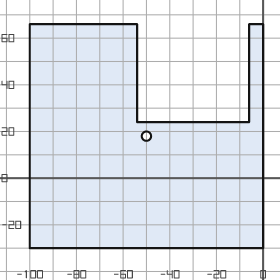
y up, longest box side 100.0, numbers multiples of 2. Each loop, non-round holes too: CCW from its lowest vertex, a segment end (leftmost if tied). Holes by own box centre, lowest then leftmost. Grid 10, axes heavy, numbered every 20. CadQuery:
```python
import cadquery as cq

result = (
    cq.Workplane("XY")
    .moveTo(-100.0, -30.0)
    .lineTo(0.0, -30.0)
    .lineTo(0.0, 66.0)
    .lineTo(-6.0, 66.0)
    .lineTo(-6.0, 24.0)
    .lineTo(-54.0, 24.0)
    .lineTo(-54.0, 66.0)
    .lineTo(-100.0, 66.0)
    .close()
    .moveTo(-50.0, 18.0)
    .circle(2.0)
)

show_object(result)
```